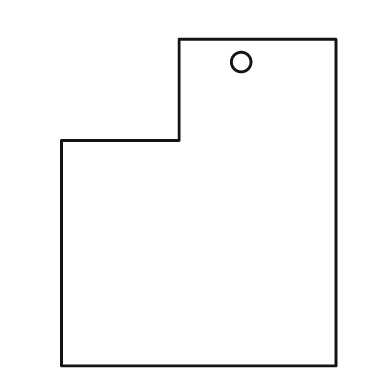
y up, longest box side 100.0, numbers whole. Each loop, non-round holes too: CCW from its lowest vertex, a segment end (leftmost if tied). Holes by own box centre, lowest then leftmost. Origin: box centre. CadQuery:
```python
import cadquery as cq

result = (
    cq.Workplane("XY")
    .moveTo(-42.0, -50.0)
    .lineTo(42.0, -50.0)
    .lineTo(42.0, 50.0)
    .lineTo(-6.0, 50.0)
    .lineTo(-6.0, 19.0)
    .lineTo(-42.0, 19.0)
    .close()
    .moveTo(13.0, 43.0)
    .circle(3.0)
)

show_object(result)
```